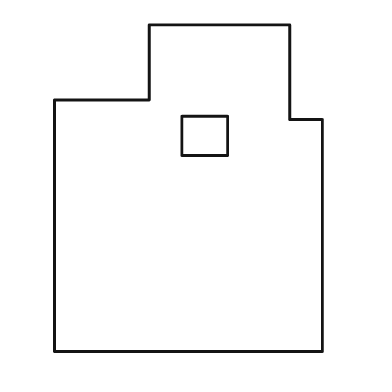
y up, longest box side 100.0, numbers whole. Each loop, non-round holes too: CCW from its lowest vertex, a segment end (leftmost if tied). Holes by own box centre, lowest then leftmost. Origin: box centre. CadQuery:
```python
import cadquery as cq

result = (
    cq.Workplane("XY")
    .moveTo(-41.0, -50.0)
    .lineTo(41.0, -50.0)
    .lineTo(41.0, 21.0)
    .lineTo(31.0, 21.0)
    .lineTo(31.0, 50.0)
    .lineTo(-12.0, 50.0)
    .lineTo(-12.0, 27.0)
    .lineTo(-41.0, 27.0)
    .close()
    .moveTo(-2.0, 10.0)
    .lineTo(12.0, 10.0)
    .lineTo(12.0, 22.0)
    .lineTo(-2.0, 22.0)
    .close()
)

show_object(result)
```